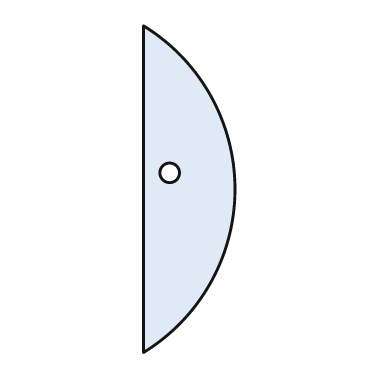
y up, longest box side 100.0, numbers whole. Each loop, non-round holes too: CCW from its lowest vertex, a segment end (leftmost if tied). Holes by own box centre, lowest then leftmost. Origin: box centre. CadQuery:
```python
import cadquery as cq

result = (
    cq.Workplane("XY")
    .moveTo(-14.0, -50.0)
    .threePointArc((14.0, 0.0), (-14.0, 50.0))
    .close()
    .moveTo(-6.0, 5.0)
    .circle(3.0)
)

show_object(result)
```